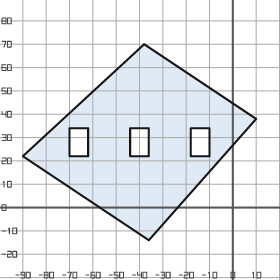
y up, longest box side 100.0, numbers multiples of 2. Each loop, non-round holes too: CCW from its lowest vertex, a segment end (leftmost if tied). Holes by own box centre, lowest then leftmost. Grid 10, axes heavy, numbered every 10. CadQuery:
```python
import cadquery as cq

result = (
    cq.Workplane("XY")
    .moveTo(-36.0, -14.0)
    .lineTo(10.0, 38.0)
    .lineTo(-38.0, 70.0)
    .lineTo(-90.0, 22.0)
    .close()
    .moveTo(-70.0, 22.0)
    .lineTo(-62.0, 22.0)
    .lineTo(-62.0, 34.0)
    .lineTo(-70.0, 34.0)
    .close()
    .moveTo(-44.0, 22.0)
    .lineTo(-36.0, 22.0)
    .lineTo(-36.0, 34.0)
    .lineTo(-44.0, 34.0)
    .close()
    .moveTo(-18.0, 22.0)
    .lineTo(-10.0, 22.0)
    .lineTo(-10.0, 34.0)
    .lineTo(-18.0, 34.0)
    .close()
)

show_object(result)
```